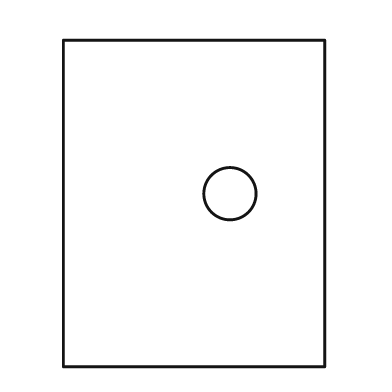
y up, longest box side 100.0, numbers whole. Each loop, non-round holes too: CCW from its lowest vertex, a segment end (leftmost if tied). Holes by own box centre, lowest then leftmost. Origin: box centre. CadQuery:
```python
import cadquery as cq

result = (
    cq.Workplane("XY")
    .moveTo(-40.0, -50.0)
    .lineTo(40.0, -50.0)
    .lineTo(40.0, 50.0)
    .lineTo(-40.0, 50.0)
    .close()
    .moveTo(11.0, 3.0)
    .circle(8.0)
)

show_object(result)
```